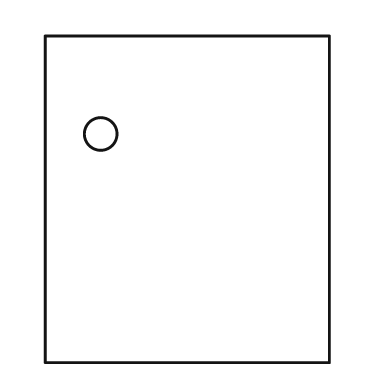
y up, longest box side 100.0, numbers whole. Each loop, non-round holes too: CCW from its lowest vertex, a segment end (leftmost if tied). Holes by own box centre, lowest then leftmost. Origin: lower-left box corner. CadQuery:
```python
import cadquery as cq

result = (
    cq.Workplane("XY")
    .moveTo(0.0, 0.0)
    .lineTo(87.0, 0.0)
    .lineTo(87.0, 100.0)
    .lineTo(0.0, 100.0)
    .close()
    .moveTo(17.0, 70.0)
    .circle(5.0)
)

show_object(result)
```